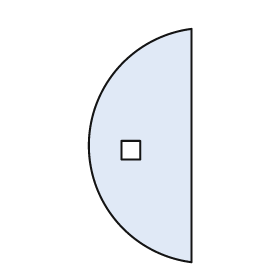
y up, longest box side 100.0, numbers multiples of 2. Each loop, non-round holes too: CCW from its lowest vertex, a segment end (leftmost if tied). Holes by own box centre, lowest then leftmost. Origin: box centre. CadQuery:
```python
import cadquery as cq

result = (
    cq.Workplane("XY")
    .moveTo(22.0, -50.0)
    .lineTo(22.0, 50.0)
    .threePointArc((-22.0, 0.0), (22.0, -50.0))
    .close()
    .moveTo(-8.0, -6.0)
    .lineTo(0.0, -6.0)
    .lineTo(0.0, 2.0)
    .lineTo(-8.0, 2.0)
    .close()
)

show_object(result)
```